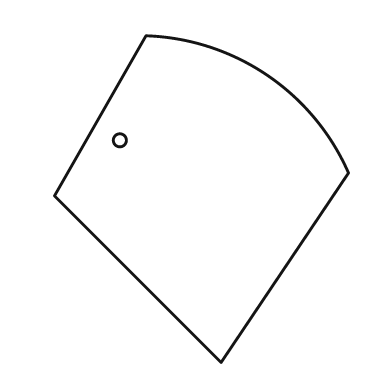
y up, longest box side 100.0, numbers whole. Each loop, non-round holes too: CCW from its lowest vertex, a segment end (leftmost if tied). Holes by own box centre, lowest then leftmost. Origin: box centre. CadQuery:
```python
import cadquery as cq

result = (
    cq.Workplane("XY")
    .moveTo(6.0, -50.0)
    .lineTo(45.0, 8.0)
    .threePointArc((20.0, 38.0), (-17.0, 50.0))
    .lineTo(-45.0, 1.0)
    .close()
    .moveTo(-25.0, 18.0)
    .circle(2.0)
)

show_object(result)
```